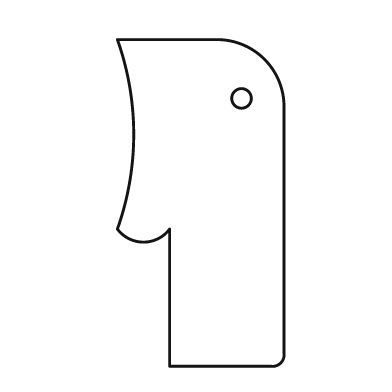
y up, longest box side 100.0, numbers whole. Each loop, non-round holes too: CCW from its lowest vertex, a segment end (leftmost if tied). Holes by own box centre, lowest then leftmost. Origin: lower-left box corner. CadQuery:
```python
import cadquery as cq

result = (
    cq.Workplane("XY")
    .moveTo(16.0, 0.0)
    .lineTo(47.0, 0.0)
    .threePointArc((50.0, 1.0), (51.0, 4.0))
    .lineTo(51.0, 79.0)
    .threePointArc((45.0, 94.0), (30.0, 100.0))
    .lineTo(0.0, 100.0)
    .threePointArc((5.0, 71.0), (0.0, 42.0))
    .threePointArc((8.0, 38.0), (16.0, 42.0))
    .close()
    .moveTo(38.0, 82.0)
    .circle(3.0)
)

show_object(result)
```